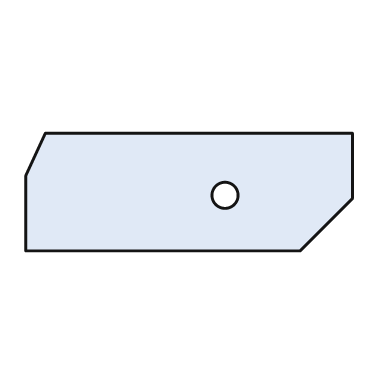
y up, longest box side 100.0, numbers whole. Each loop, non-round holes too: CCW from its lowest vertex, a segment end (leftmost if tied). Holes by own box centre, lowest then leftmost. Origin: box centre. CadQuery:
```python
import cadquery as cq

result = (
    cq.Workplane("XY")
    .moveTo(-50.0, -18.0)
    .lineTo(34.0, -18.0)
    .lineTo(50.0, -2.0)
    .lineTo(50.0, 18.0)
    .lineTo(-44.0, 18.0)
    .lineTo(-50.0, 5.0)
    .close()
    .moveTo(11.0, -1.0)
    .circle(4.0)
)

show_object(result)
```